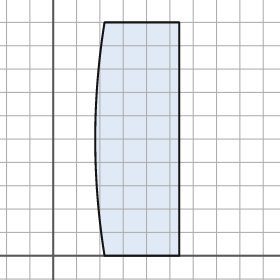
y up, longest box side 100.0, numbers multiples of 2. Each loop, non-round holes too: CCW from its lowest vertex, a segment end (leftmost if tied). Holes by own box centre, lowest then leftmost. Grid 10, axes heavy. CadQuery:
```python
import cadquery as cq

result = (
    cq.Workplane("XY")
    .moveTo(22.0, 0.0)
    .lineTo(54.0, 0.0)
    .lineTo(54.0, 100.0)
    .lineTo(22.0, 100.0)
    .threePointArc((18.0, 50.0), (22.0, 0.0))
    .close()
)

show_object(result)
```